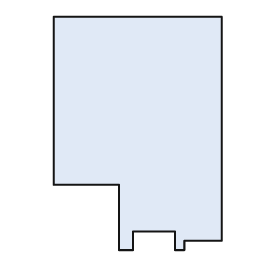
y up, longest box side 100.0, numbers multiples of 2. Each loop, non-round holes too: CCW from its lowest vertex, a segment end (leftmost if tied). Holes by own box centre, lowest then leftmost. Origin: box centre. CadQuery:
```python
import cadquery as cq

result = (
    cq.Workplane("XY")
    .moveTo(-8.0, -50.0)
    .lineTo(-2.0, -50.0)
    .lineTo(-2.0, -42.0)
    .lineTo(16.0, -42.0)
    .lineTo(16.0, -50.0)
    .lineTo(20.0, -50.0)
    .lineTo(20.0, -46.0)
    .lineTo(36.0, -46.0)
    .lineTo(36.0, 50.0)
    .lineTo(-36.0, 50.0)
    .lineTo(-36.0, -22.0)
    .lineTo(-8.0, -22.0)
    .close()
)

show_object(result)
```